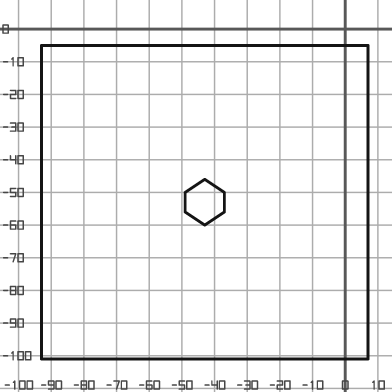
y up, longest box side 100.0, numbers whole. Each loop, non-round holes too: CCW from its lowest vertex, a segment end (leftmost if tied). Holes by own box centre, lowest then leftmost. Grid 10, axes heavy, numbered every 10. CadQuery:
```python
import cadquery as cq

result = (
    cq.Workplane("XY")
    .moveTo(-93.0, -101.0)
    .lineTo(7.0, -101.0)
    .lineTo(7.0, -5.0)
    .lineTo(-93.0, -5.0)
    .close()
    .moveTo(-43.0, -60.0)
    .lineTo(-37.0, -56.0)
    .lineTo(-37.0, -50.0)
    .lineTo(-43.0, -46.0)
    .lineTo(-49.0, -50.0)
    .lineTo(-49.0, -56.0)
    .close()
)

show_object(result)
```